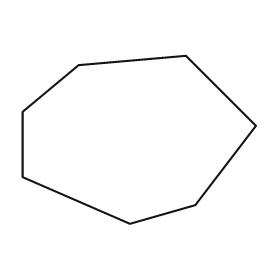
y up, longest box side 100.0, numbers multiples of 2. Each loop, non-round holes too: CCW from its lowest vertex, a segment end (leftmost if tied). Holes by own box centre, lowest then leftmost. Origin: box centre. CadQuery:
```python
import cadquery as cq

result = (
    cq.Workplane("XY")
    .moveTo(-4.0, -36.0)
    .lineTo(24.0, -28.0)
    .lineTo(50.0, 6.0)
    .lineTo(20.0, 36.0)
    .lineTo(-26.0, 32.0)
    .lineTo(-50.0, 12.0)
    .lineTo(-50.0, -16.0)
    .close()
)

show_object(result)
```